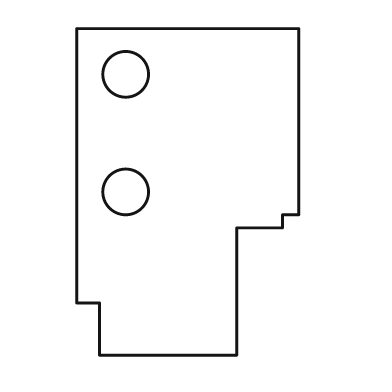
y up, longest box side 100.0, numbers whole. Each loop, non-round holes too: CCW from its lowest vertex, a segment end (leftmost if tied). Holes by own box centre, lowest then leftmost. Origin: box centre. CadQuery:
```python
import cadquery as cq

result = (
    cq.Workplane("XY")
    .moveTo(-27.0, -50.0)
    .lineTo(15.0, -50.0)
    .lineTo(15.0, -11.0)
    .lineTo(29.0, -11.0)
    .lineTo(29.0, -7.0)
    .lineTo(34.0, -7.0)
    .lineTo(34.0, 50.0)
    .lineTo(-34.0, 50.0)
    .lineTo(-34.0, -34.0)
    .lineTo(-27.0, -34.0)
    .close()
    .moveTo(-19.0, 0.0)
    .circle(7.0)
    .moveTo(-19.0, 36.0)
    .circle(7.0)
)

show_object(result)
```